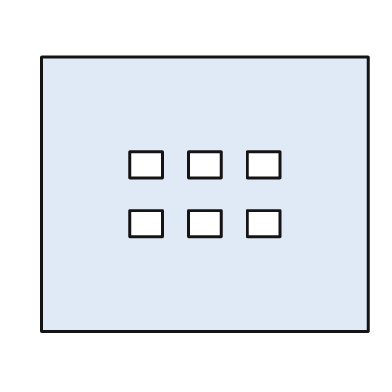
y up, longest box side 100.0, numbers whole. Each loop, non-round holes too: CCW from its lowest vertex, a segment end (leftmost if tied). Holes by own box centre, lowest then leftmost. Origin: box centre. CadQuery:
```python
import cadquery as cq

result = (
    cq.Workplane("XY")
    .moveTo(-50.0, -42.0)
    .lineTo(50.0, -42.0)
    .lineTo(50.0, 42.0)
    .lineTo(-50.0, 42.0)
    .close()
    .moveTo(-23.0, -13.0)
    .lineTo(-13.0, -13.0)
    .lineTo(-13.0, -5.0)
    .lineTo(-23.0, -5.0)
    .close()
    .moveTo(-5.0, -13.0)
    .lineTo(5.0, -13.0)
    .lineTo(5.0, -5.0)
    .lineTo(-5.0, -5.0)
    .close()
    .moveTo(13.0, -13.0)
    .lineTo(23.0, -13.0)
    .lineTo(23.0, -5.0)
    .lineTo(13.0, -5.0)
    .close()
    .moveTo(-23.0, 5.0)
    .lineTo(-13.0, 5.0)
    .lineTo(-13.0, 13.0)
    .lineTo(-23.0, 13.0)
    .close()
    .moveTo(-5.0, 5.0)
    .lineTo(5.0, 5.0)
    .lineTo(5.0, 13.0)
    .lineTo(-5.0, 13.0)
    .close()
    .moveTo(13.0, 5.0)
    .lineTo(23.0, 5.0)
    .lineTo(23.0, 13.0)
    .lineTo(13.0, 13.0)
    .close()
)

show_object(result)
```